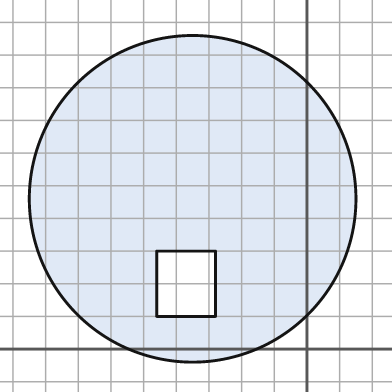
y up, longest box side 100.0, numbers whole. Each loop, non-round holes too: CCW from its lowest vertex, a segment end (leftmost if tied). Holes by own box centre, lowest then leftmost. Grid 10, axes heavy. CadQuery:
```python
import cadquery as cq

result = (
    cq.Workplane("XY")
    .moveTo(-35.0, 46.0)
    .circle(50.0)
    .moveTo(-46.0, 10.0)
    .lineTo(-28.0, 10.0)
    .lineTo(-28.0, 30.0)
    .lineTo(-46.0, 30.0)
    .close()
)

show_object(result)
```